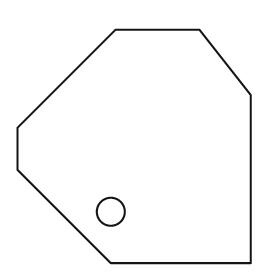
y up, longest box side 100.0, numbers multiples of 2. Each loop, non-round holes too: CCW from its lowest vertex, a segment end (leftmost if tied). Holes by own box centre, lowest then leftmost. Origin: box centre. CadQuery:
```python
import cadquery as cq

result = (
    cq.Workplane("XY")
    .moveTo(-10.0, -50.0)
    .lineTo(50.0, -50.0)
    .lineTo(50.0, 22.0)
    .lineTo(28.0, 50.0)
    .lineTo(-8.0, 50.0)
    .lineTo(-50.0, 8.0)
    .lineTo(-50.0, -10.0)
    .close()
    .moveTo(-10.0, -28.0)
    .circle(6.0)
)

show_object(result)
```